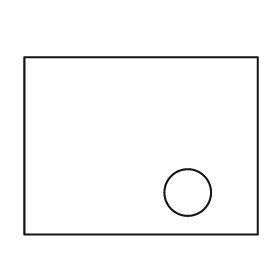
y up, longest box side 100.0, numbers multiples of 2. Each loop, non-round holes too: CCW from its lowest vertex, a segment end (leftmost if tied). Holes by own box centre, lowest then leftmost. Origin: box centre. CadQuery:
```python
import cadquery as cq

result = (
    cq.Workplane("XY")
    .moveTo(-50.0, -38.0)
    .lineTo(50.0, -38.0)
    .lineTo(50.0, 38.0)
    .lineTo(-50.0, 38.0)
    .close()
    .moveTo(20.0, -20.0)
    .circle(10.0)
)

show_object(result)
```